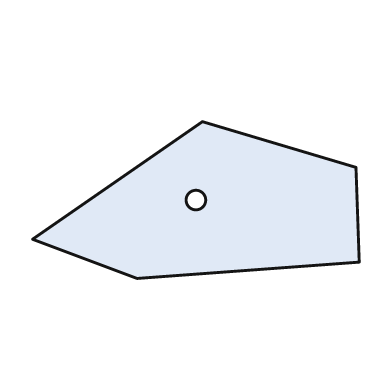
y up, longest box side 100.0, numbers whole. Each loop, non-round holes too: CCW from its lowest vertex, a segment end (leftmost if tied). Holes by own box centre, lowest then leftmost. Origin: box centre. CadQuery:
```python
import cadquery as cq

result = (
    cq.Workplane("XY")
    .moveTo(-18.0, -24.0)
    .lineTo(50.0, -19.0)
    .lineTo(49.0, 10.0)
    .lineTo(2.0, 24.0)
    .lineTo(-50.0, -12.0)
    .close()
    .moveTo(0.0, 0.0)
    .circle(3.0)
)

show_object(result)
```